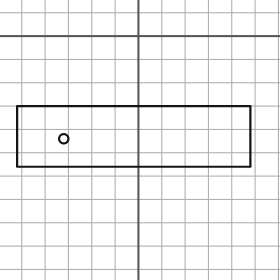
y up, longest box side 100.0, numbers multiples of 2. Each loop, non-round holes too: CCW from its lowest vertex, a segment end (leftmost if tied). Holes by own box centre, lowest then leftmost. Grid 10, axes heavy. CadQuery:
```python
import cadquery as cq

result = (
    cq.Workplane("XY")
    .moveTo(-52.0, -56.0)
    .lineTo(48.0, -56.0)
    .lineTo(48.0, -30.0)
    .lineTo(-52.0, -30.0)
    .close()
    .moveTo(-32.0, -44.0)
    .circle(2.0)
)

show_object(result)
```